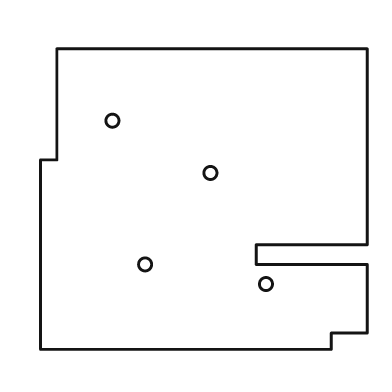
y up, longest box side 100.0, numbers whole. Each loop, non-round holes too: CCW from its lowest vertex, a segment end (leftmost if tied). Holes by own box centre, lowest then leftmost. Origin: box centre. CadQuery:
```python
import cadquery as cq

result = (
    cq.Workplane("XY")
    .moveTo(-50.0, -46.0)
    .lineTo(39.0, -46.0)
    .lineTo(39.0, -41.0)
    .lineTo(50.0, -41.0)
    .lineTo(50.0, -20.0)
    .lineTo(16.0, -20.0)
    .lineTo(16.0, -14.0)
    .lineTo(50.0, -14.0)
    .lineTo(50.0, 46.0)
    .lineTo(-45.0, 46.0)
    .lineTo(-45.0, 12.0)
    .lineTo(-50.0, 12.0)
    .close()
    .moveTo(19.0, -26.0)
    .circle(2.0)
    .moveTo(-18.0, -20.0)
    .circle(2.0)
    .moveTo(2.0, 8.0)
    .circle(2.0)
    .moveTo(-28.0, 24.0)
    .circle(2.0)
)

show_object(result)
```